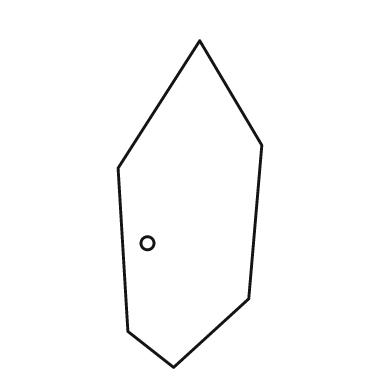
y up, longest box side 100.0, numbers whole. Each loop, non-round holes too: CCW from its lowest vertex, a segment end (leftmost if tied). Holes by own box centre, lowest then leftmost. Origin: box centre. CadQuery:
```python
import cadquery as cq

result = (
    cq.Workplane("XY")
    .moveTo(-5.0, -50.0)
    .lineTo(18.0, -29.0)
    .lineTo(22.0, 18.0)
    .lineTo(3.0, 50.0)
    .lineTo(-22.0, 11.0)
    .lineTo(-19.0, -39.0)
    .close()
    .moveTo(-13.0, -12.0)
    .circle(2.0)
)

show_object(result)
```